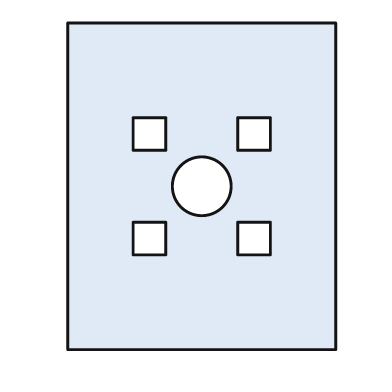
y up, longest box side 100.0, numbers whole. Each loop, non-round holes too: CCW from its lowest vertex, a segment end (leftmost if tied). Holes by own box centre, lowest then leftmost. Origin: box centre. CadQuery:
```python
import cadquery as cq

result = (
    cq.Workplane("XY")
    .moveTo(-41.0, -50.0)
    .lineTo(41.0, -50.0)
    .lineTo(41.0, 50.0)
    .lineTo(-41.0, 50.0)
    .close()
    .moveTo(-21.0, -21.0)
    .lineTo(-11.0, -21.0)
    .lineTo(-11.0, -11.0)
    .lineTo(-21.0, -11.0)
    .close()
    .moveTo(11.0, -21.0)
    .lineTo(21.0, -21.0)
    .lineTo(21.0, -11.0)
    .lineTo(11.0, -11.0)
    .close()
    .moveTo(0.0, 0.0)
    .circle(9.0)
    .moveTo(-21.0, 11.0)
    .lineTo(-11.0, 11.0)
    .lineTo(-11.0, 21.0)
    .lineTo(-21.0, 21.0)
    .close()
    .moveTo(11.0, 11.0)
    .lineTo(21.0, 11.0)
    .lineTo(21.0, 21.0)
    .lineTo(11.0, 21.0)
    .close()
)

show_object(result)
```